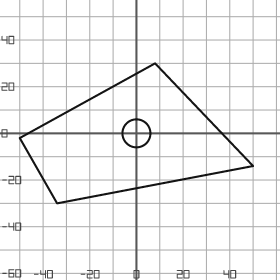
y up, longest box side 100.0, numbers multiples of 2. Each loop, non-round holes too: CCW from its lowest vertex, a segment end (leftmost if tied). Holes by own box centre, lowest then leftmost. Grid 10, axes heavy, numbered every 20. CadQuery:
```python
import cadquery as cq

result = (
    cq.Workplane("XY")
    .moveTo(-34.0, -30.0)
    .lineTo(50.0, -14.0)
    .lineTo(8.0, 30.0)
    .lineTo(-50.0, -2.0)
    .close()
    .moveTo(0.0, 0.0)
    .circle(6.0)
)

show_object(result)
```